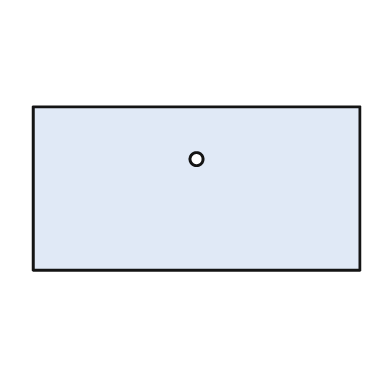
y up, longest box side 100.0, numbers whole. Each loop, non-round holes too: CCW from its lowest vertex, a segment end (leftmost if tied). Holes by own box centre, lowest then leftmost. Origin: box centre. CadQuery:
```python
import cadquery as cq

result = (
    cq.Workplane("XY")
    .moveTo(-50.0, -25.0)
    .lineTo(50.0, -25.0)
    .lineTo(50.0, 25.0)
    .lineTo(-50.0, 25.0)
    .close()
    .moveTo(0.0, 9.0)
    .circle(2.0)
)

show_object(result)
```